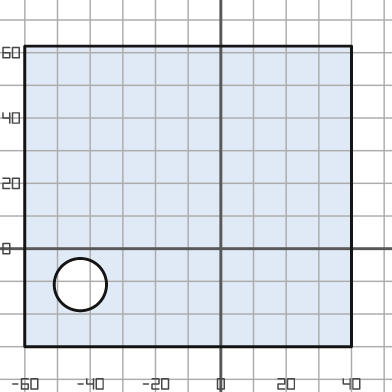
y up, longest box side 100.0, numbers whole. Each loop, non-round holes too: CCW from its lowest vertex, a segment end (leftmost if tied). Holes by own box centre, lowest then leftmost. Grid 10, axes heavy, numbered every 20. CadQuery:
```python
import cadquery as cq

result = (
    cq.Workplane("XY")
    .moveTo(-60.0, -30.0)
    .lineTo(40.0, -30.0)
    .lineTo(40.0, 62.0)
    .lineTo(-60.0, 62.0)
    .close()
    .moveTo(-43.0, -11.0)
    .circle(8.0)
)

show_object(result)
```